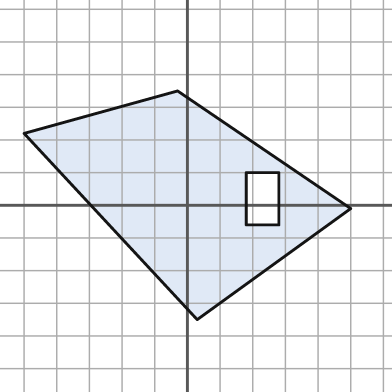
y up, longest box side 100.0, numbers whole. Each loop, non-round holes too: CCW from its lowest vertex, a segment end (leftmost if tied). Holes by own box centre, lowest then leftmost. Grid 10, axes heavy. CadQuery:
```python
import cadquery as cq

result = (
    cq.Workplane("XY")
    .moveTo(3.0, -35.0)
    .lineTo(50.0, -1.0)
    .lineTo(-3.0, 35.0)
    .lineTo(-50.0, 22.0)
    .close()
    .moveTo(18.0, -6.0)
    .lineTo(28.0, -6.0)
    .lineTo(28.0, 10.0)
    .lineTo(18.0, 10.0)
    .close()
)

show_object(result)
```